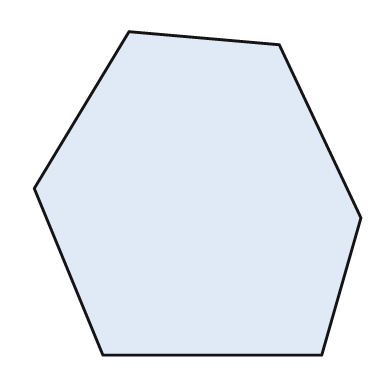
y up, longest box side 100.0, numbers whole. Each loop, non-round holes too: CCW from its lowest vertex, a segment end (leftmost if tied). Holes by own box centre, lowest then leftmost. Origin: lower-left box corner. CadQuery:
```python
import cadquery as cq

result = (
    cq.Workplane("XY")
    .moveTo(21.0, 0.0)
    .lineTo(88.0, 0.0)
    .lineTo(100.0, 42.0)
    .lineTo(75.0, 95.0)
    .lineTo(29.0, 99.0)
    .lineTo(0.0, 51.0)
    .close()
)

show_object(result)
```